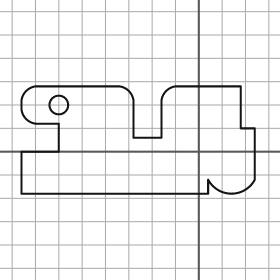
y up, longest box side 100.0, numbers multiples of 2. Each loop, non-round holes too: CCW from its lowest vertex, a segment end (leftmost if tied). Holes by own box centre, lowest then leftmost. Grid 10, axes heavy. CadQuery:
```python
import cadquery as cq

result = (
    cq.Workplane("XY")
    .moveTo(-76.0, -18.0)
    .lineTo(4.0, -18.0)
    .lineTo(4.0, -12.0)
    .threePointArc((14.0, -18.0), (24.0, -12.0))
    .lineTo(24.0, 10.0)
    .lineTo(18.0, 10.0)
    .lineTo(18.0, 28.0)
    .lineTo(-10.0, 28.0)
    .threePointArc((-14.0, 26.0), (-16.0, 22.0))
    .lineTo(-16.0, 6.0)
    .lineTo(-28.0, 6.0)
    .lineTo(-28.0, 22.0)
    .threePointArc((-30.0, 26.0), (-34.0, 28.0))
    .lineTo(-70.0, 28.0)
    .threePointArc((-74.0, 26.0), (-76.0, 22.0))
    .lineTo(-76.0, 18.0)
    .threePointArc((-74.0, 14.0), (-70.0, 12.0))
    .lineTo(-60.0, 12.0)
    .lineTo(-60.0, 0.0)
    .lineTo(-76.0, 0.0)
    .close()
    .moveTo(-60.0, 20.0)
    .circle(4.0)
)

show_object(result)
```